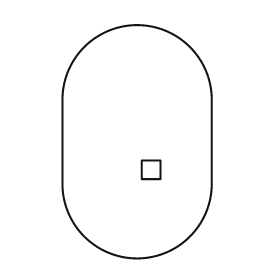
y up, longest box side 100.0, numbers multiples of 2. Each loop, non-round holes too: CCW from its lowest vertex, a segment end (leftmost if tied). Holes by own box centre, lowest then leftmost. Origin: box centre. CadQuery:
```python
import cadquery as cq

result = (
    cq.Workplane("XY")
    .moveTo(-32.0, -18.0)
    .threePointArc((0.0, -50.0), (32.0, -18.0))
    .lineTo(32.0, 18.0)
    .threePointArc((0.0, 50.0), (-32.0, 18.0))
    .close()
    .moveTo(2.0, -16.0)
    .lineTo(10.0, -16.0)
    .lineTo(10.0, -8.0)
    .lineTo(2.0, -8.0)
    .close()
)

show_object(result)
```